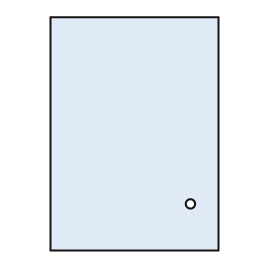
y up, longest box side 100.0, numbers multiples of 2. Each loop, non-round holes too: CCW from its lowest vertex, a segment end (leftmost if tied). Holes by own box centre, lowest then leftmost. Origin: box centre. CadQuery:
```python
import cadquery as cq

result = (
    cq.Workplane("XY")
    .moveTo(-36.0, -50.0)
    .lineTo(36.0, -50.0)
    .lineTo(36.0, 50.0)
    .lineTo(-36.0, 50.0)
    .close()
    .moveTo(24.0, -30.0)
    .circle(2.0)
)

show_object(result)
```